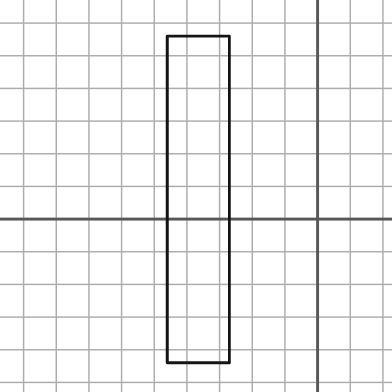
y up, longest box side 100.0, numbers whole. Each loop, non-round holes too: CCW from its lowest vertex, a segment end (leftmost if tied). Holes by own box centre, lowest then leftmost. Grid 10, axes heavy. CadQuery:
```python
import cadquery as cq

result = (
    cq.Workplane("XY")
    .moveTo(-46.0, -44.0)
    .lineTo(-27.0, -44.0)
    .lineTo(-27.0, 56.0)
    .lineTo(-46.0, 56.0)
    .close()
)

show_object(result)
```